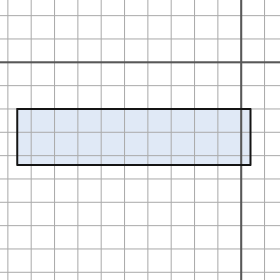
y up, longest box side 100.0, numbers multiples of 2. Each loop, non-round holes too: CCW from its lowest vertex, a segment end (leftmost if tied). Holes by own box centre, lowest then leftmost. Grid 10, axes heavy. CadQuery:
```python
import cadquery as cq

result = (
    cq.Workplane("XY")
    .moveTo(-96.0, -44.0)
    .lineTo(4.0, -44.0)
    .lineTo(4.0, -20.0)
    .lineTo(-96.0, -20.0)
    .close()
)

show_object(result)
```